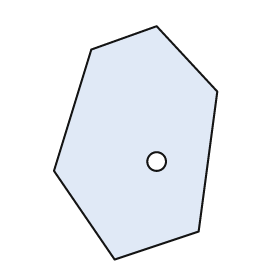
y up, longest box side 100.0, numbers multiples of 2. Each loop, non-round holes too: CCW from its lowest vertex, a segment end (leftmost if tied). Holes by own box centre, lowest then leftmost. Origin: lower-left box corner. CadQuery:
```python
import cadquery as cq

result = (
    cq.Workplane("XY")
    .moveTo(26.0, 0.0)
    .lineTo(62.0, 12.0)
    .lineTo(70.0, 72.0)
    .lineTo(44.0, 100.0)
    .lineTo(16.0, 90.0)
    .lineTo(0.0, 38.0)
    .close()
    .moveTo(44.0, 42.0)
    .circle(4.0)
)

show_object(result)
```